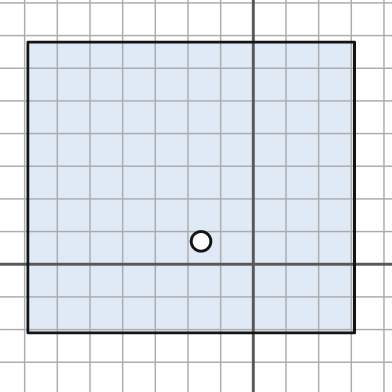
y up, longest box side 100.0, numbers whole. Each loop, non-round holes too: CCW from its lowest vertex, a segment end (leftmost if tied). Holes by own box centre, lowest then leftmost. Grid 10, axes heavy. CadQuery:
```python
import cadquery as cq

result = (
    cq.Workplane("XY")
    .moveTo(-69.0, -21.0)
    .lineTo(31.0, -21.0)
    .lineTo(31.0, 68.0)
    .lineTo(-69.0, 68.0)
    .close()
    .moveTo(-16.0, 7.0)
    .circle(3.0)
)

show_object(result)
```